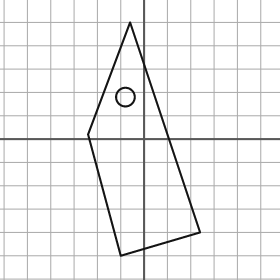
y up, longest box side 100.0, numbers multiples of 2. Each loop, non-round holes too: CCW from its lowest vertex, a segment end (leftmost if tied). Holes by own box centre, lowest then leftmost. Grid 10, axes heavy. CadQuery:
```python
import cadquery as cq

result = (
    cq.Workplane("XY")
    .moveTo(-10.0, -50.0)
    .lineTo(24.0, -40.0)
    .lineTo(-6.0, 50.0)
    .lineTo(-24.0, 2.0)
    .close()
    .moveTo(-8.0, 18.0)
    .circle(4.0)
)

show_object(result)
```